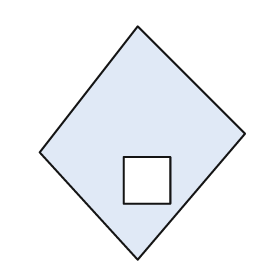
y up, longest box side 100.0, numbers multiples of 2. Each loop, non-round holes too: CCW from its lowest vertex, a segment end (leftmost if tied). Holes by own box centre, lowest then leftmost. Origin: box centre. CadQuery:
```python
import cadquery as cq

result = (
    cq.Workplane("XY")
    .moveTo(-2.0, -50.0)
    .lineTo(44.0, 4.0)
    .lineTo(-2.0, 50.0)
    .lineTo(-44.0, -4.0)
    .close()
    .moveTo(-8.0, -26.0)
    .lineTo(12.0, -26.0)
    .lineTo(12.0, -6.0)
    .lineTo(-8.0, -6.0)
    .close()
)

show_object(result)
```